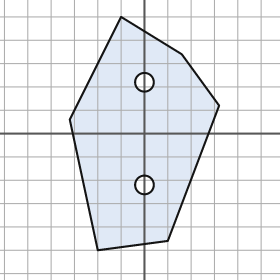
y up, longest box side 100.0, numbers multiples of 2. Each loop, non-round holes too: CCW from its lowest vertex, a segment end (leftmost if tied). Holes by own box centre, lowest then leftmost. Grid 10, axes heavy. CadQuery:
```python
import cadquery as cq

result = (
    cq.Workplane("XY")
    .moveTo(-20.0, -50.0)
    .lineTo(10.0, -46.0)
    .lineTo(32.0, 12.0)
    .lineTo(16.0, 34.0)
    .lineTo(-10.0, 50.0)
    .lineTo(-32.0, 6.0)
    .close()
    .moveTo(0.0, -22.0)
    .circle(4.0)
    .moveTo(0.0, 22.0)
    .circle(4.0)
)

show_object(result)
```